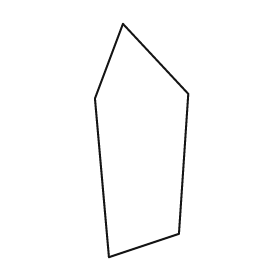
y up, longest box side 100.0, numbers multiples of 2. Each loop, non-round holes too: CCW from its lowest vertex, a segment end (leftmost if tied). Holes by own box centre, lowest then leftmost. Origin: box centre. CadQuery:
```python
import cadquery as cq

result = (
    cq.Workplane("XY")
    .moveTo(-14.0, -50.0)
    .lineTo(16.0, -40.0)
    .lineTo(20.0, 20.0)
    .lineTo(-8.0, 50.0)
    .lineTo(-20.0, 18.0)
    .close()
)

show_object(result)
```